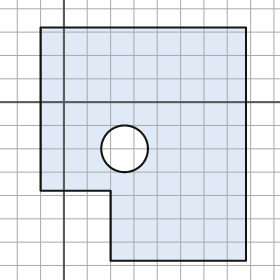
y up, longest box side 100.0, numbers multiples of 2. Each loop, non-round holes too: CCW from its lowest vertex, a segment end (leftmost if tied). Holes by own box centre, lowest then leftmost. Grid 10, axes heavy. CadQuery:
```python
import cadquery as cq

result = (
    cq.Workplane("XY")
    .moveTo(20.0, -68.0)
    .lineTo(78.0, -68.0)
    .lineTo(78.0, 32.0)
    .lineTo(-10.0, 32.0)
    .lineTo(-10.0, -38.0)
    .lineTo(20.0, -38.0)
    .close()
    .moveTo(26.0, -20.0)
    .circle(10.0)
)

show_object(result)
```